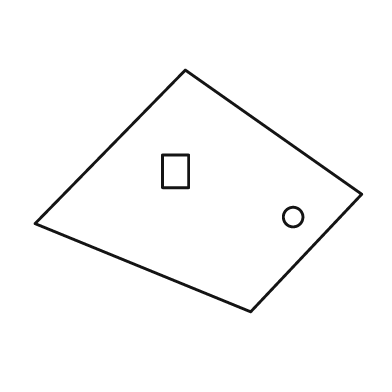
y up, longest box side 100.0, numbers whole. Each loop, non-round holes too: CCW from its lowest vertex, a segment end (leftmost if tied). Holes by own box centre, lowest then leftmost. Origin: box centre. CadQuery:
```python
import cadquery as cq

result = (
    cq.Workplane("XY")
    .moveTo(16.0, -37.0)
    .lineTo(50.0, -1.0)
    .lineTo(-4.0, 37.0)
    .lineTo(-50.0, -10.0)
    .close()
    .moveTo(29.0, -8.0)
    .circle(3.0)
    .moveTo(-11.0, 1.0)
    .lineTo(-3.0, 1.0)
    .lineTo(-3.0, 11.0)
    .lineTo(-11.0, 11.0)
    .close()
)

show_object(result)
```